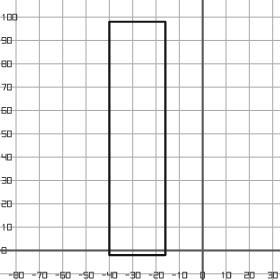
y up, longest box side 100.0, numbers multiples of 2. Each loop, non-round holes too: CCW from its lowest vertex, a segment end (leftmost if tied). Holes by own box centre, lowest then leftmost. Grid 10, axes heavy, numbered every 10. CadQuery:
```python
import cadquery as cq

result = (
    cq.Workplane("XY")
    .moveTo(-40.0, -2.0)
    .lineTo(-16.0, -2.0)
    .lineTo(-16.0, 98.0)
    .lineTo(-40.0, 98.0)
    .close()
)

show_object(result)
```